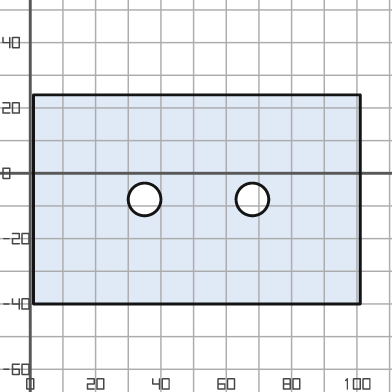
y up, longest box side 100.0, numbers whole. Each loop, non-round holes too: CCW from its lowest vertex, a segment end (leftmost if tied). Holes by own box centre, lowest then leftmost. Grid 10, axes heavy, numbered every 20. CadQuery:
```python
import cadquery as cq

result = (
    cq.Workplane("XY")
    .moveTo(1.0, -40.0)
    .lineTo(101.0, -40.0)
    .lineTo(101.0, 24.0)
    .lineTo(1.0, 24.0)
    .close()
    .moveTo(35.0, -8.0)
    .circle(5.0)
    .moveTo(68.0, -8.0)
    .circle(5.0)
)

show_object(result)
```